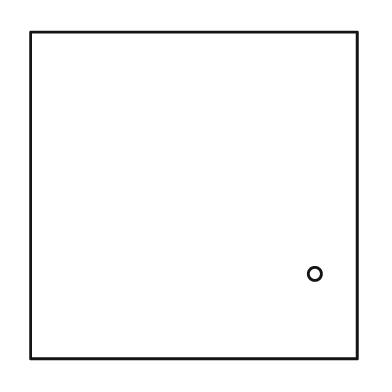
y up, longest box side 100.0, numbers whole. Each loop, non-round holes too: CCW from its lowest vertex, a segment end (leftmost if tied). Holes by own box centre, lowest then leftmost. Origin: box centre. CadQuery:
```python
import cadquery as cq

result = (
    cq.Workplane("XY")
    .moveTo(-50.0, -50.0)
    .lineTo(50.0, -50.0)
    .lineTo(50.0, 50.0)
    .lineTo(-50.0, 50.0)
    .close()
    .moveTo(37.0, -24.0)
    .circle(2.0)
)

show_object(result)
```